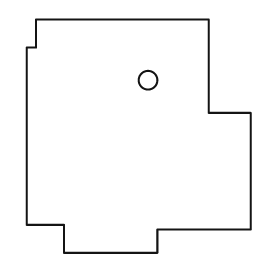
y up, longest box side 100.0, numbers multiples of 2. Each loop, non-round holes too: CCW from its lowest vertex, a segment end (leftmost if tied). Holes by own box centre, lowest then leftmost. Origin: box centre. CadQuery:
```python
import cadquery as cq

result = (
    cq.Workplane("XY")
    .moveTo(-32.0, -50.0)
    .lineTo(8.0, -50.0)
    .lineTo(8.0, -40.0)
    .lineTo(48.0, -40.0)
    .lineTo(48.0, 10.0)
    .lineTo(30.0, 10.0)
    .lineTo(30.0, 50.0)
    .lineTo(-44.0, 50.0)
    .lineTo(-44.0, 38.0)
    .lineTo(-48.0, 38.0)
    .lineTo(-48.0, -38.0)
    .lineTo(-32.0, -38.0)
    .close()
    .moveTo(4.0, 24.0)
    .circle(4.0)
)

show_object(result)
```